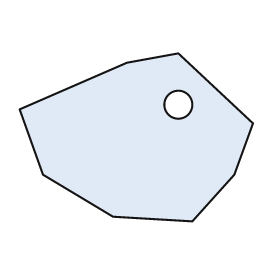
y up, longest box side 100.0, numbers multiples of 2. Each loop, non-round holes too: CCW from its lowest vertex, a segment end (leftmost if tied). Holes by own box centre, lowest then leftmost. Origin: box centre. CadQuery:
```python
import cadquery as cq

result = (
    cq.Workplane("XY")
    .moveTo(24.0, -36.0)
    .lineTo(42.0, -16.0)
    .lineTo(50.0, 6.0)
    .lineTo(18.0, 36.0)
    .lineTo(-4.0, 32.0)
    .lineTo(-50.0, 12.0)
    .lineTo(-40.0, -16.0)
    .lineTo(-10.0, -34.0)
    .close()
    .moveTo(18.0, 14.0)
    .circle(6.0)
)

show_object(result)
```